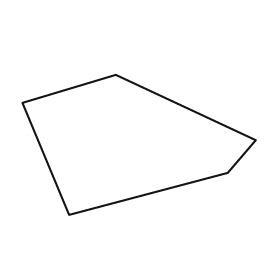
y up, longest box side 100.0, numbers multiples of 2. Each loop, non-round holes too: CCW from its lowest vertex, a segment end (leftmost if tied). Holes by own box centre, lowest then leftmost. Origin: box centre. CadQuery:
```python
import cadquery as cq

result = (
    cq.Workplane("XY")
    .moveTo(-30.0, -30.0)
    .lineTo(38.0, -12.0)
    .lineTo(50.0, 2.0)
    .lineTo(-10.0, 30.0)
    .lineTo(-50.0, 18.0)
    .close()
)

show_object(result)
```